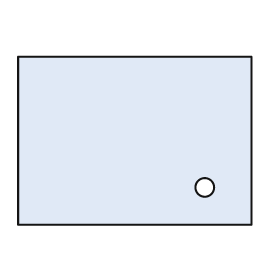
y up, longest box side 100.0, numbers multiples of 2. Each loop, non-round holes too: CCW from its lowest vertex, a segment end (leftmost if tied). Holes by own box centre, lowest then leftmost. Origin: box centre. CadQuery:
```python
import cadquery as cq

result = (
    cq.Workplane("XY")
    .moveTo(-50.0, -36.0)
    .lineTo(50.0, -36.0)
    .lineTo(50.0, 36.0)
    .lineTo(-50.0, 36.0)
    .close()
    .moveTo(30.0, -20.0)
    .circle(4.0)
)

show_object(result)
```